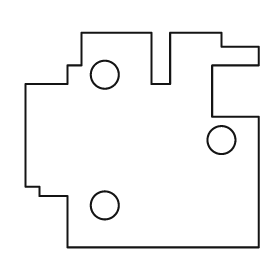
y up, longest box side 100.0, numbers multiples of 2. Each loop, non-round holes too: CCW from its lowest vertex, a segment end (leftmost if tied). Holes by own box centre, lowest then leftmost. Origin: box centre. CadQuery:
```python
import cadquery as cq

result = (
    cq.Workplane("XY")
    .moveTo(-32.0, -46.0)
    .lineTo(50.0, -46.0)
    .lineTo(50.0, 10.0)
    .lineTo(30.0, 10.0)
    .lineTo(30.0, 32.0)
    .lineTo(50.0, 32.0)
    .lineTo(50.0, 40.0)
    .lineTo(34.0, 40.0)
    .lineTo(34.0, 46.0)
    .lineTo(12.0, 46.0)
    .lineTo(12.0, 24.0)
    .lineTo(4.0, 24.0)
    .lineTo(4.0, 46.0)
    .lineTo(-26.0, 46.0)
    .lineTo(-26.0, 32.0)
    .lineTo(-32.0, 32.0)
    .lineTo(-32.0, 24.0)
    .lineTo(-50.0, 24.0)
    .lineTo(-50.0, -20.0)
    .lineTo(-44.0, -20.0)
    .lineTo(-44.0, -24.0)
    .lineTo(-32.0, -24.0)
    .close()
    .moveTo(-16.0, -28.0)
    .circle(6.0)
    .moveTo(34.0, 0.0)
    .circle(6.0)
    .moveTo(-16.0, 28.0)
    .circle(6.0)
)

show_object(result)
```